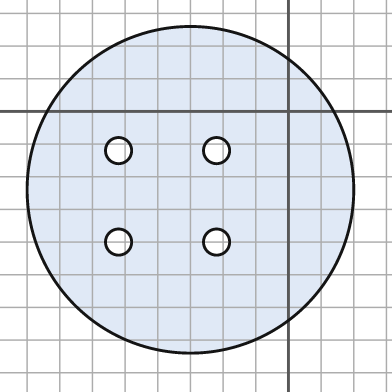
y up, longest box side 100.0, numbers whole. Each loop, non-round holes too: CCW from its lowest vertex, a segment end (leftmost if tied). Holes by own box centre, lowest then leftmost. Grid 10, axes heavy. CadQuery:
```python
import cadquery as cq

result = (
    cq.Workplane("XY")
    .moveTo(-30.0, -24.0)
    .circle(50.0)
    .moveTo(-52.0, -40.0)
    .circle(4.0)
    .moveTo(-22.0, -40.0)
    .circle(4.0)
    .moveTo(-52.0, -12.0)
    .circle(4.0)
    .moveTo(-22.0, -12.0)
    .circle(4.0)
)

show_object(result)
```